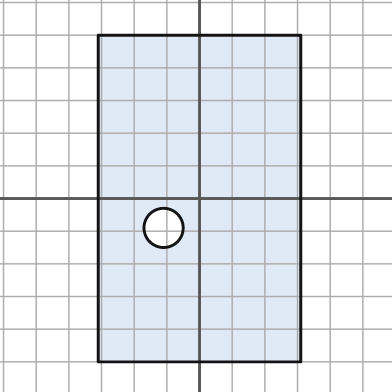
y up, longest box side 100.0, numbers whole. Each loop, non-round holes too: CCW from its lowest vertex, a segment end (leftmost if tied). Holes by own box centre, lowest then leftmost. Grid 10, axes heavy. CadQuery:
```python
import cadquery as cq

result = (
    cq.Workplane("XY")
    .moveTo(-31.0, -50.0)
    .lineTo(31.0, -50.0)
    .lineTo(31.0, 50.0)
    .lineTo(-31.0, 50.0)
    .close()
    .moveTo(-11.0, -9.0)
    .circle(6.0)
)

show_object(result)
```